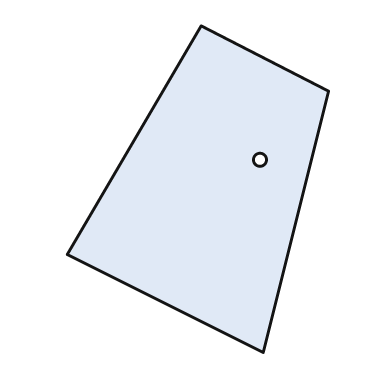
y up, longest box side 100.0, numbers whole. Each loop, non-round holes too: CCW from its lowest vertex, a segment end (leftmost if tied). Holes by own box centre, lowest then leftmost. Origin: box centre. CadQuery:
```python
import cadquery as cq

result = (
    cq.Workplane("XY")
    .moveTo(20.0, -50.0)
    .lineTo(40.0, 30.0)
    .lineTo(1.0, 50.0)
    .lineTo(-40.0, -20.0)
    .close()
    .moveTo(19.0, 9.0)
    .circle(2.0)
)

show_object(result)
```